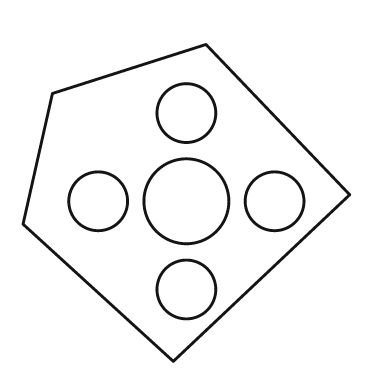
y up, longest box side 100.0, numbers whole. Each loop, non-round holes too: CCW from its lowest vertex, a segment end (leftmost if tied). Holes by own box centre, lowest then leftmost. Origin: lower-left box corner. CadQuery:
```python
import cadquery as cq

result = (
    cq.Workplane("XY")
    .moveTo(46.0, 0.0)
    .lineTo(100.0, 51.0)
    .lineTo(56.0, 97.0)
    .lineTo(9.0, 82.0)
    .lineTo(0.0, 42.0)
    .close()
    .moveTo(50.0, 22.0)
    .circle(9.0)
    .moveTo(23.0, 49.0)
    .circle(9.0)
    .moveTo(50.0, 49.0)
    .circle(13.0)
    .moveTo(77.0, 49.0)
    .circle(9.0)
    .moveTo(50.0, 76.0)
    .circle(9.0)
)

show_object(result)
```